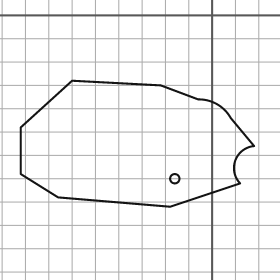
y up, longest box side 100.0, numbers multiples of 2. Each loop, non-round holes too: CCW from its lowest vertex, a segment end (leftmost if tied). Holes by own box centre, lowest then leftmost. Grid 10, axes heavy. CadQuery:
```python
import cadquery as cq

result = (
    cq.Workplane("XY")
    .moveTo(-18.0, -82.0)
    .lineTo(12.0, -72.0)
    .threePointArc((10.0, -62.0), (18.0, -56.0))
    .lineTo(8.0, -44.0)
    .threePointArc((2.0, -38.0), (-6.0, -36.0))
    .lineTo(-22.0, -30.0)
    .lineTo(-60.0, -28.0)
    .lineTo(-82.0, -48.0)
    .lineTo(-82.0, -68.0)
    .lineTo(-66.0, -78.0)
    .close()
    .moveTo(-16.0, -70.0)
    .circle(2.0)
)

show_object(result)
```